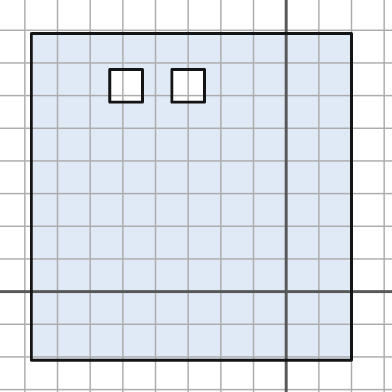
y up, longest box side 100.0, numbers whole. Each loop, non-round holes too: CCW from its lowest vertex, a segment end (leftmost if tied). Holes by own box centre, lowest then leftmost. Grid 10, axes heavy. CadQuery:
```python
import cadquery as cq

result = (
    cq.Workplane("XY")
    .moveTo(-78.0, -21.0)
    .lineTo(20.0, -21.0)
    .lineTo(20.0, 79.0)
    .lineTo(-78.0, 79.0)
    .close()
    .moveTo(-54.0, 58.0)
    .lineTo(-44.0, 58.0)
    .lineTo(-44.0, 68.0)
    .lineTo(-54.0, 68.0)
    .close()
    .moveTo(-35.0, 58.0)
    .lineTo(-25.0, 58.0)
    .lineTo(-25.0, 68.0)
    .lineTo(-35.0, 68.0)
    .close()
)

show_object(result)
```